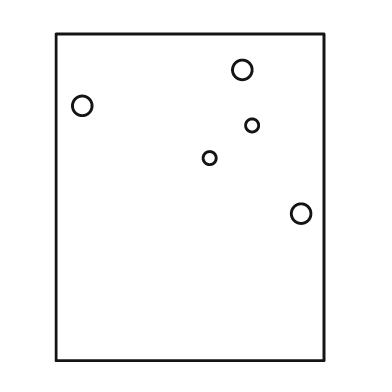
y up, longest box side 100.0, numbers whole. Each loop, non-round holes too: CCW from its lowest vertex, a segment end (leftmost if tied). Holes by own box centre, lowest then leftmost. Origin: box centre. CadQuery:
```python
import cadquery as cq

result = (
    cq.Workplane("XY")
    .moveTo(-41.0, -50.0)
    .lineTo(41.0, -50.0)
    .lineTo(41.0, 50.0)
    .lineTo(-41.0, 50.0)
    .close()
    .moveTo(34.0, -5.0)
    .circle(3.0)
    .moveTo(6.0, 12.0)
    .circle(2.0)
    .moveTo(19.0, 22.0)
    .circle(2.0)
    .moveTo(-33.0, 28.0)
    .circle(3.0)
    .moveTo(16.0, 39.0)
    .circle(3.0)
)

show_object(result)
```